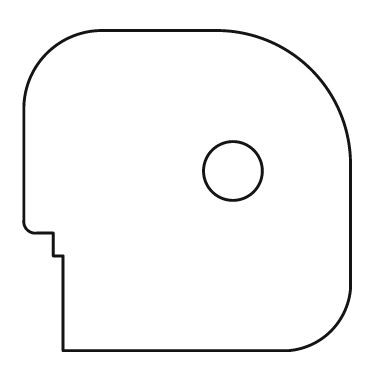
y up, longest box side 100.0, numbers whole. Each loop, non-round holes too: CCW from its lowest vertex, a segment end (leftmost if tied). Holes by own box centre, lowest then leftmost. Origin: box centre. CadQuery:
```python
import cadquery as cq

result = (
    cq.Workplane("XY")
    .moveTo(-38.0, -49.0)
    .lineTo(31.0, -49.0)
    .threePointArc((44.0, -43.0), (50.0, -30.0))
    .lineTo(50.0, 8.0)
    .threePointArc((38.0, 37.0), (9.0, 49.0))
    .lineTo(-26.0, 49.0)
    .threePointArc((-43.0, 42.0), (-50.0, 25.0))
    .lineTo(-50.0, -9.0)
    .threePointArc((-49.0, -12.0), (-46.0, -13.0))
    .lineTo(-41.0, -13.0)
    .lineTo(-41.0, -20.0)
    .lineTo(-38.0, -20.0)
    .close()
    .moveTo(14.0, 6.0)
    .circle(9.0)
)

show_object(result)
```